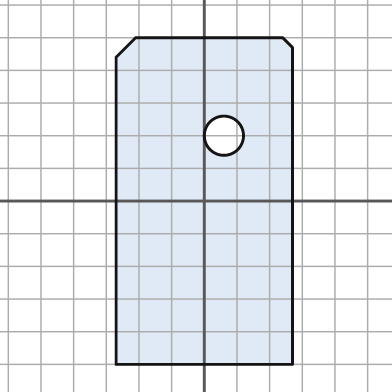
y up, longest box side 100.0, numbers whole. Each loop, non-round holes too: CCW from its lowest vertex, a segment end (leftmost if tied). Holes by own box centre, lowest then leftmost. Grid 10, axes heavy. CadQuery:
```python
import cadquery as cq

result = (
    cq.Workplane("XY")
    .moveTo(-27.0, -50.0)
    .lineTo(27.0, -50.0)
    .lineTo(27.0, 47.0)
    .lineTo(24.0, 50.0)
    .lineTo(-21.0, 50.0)
    .lineTo(-27.0, 44.0)
    .close()
    .moveTo(6.0, 20.0)
    .circle(6.0)
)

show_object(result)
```